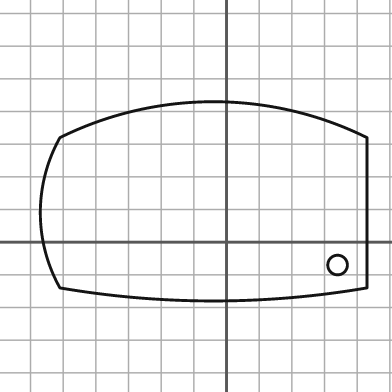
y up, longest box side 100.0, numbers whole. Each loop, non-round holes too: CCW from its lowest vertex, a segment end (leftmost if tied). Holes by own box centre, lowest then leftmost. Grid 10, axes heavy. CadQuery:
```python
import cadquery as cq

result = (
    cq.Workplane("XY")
    .moveTo(-51.0, -14.0)
    .threePointArc((-4.0, -18.0), (43.0, -14.0))
    .lineTo(43.0, 32.0)
    .threePointArc((-4.0, 43.0), (-51.0, 32.0))
    .threePointArc((-57.0, 9.0), (-51.0, -14.0))
    .close()
    .moveTo(34.0, -7.0)
    .circle(3.0)
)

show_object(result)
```